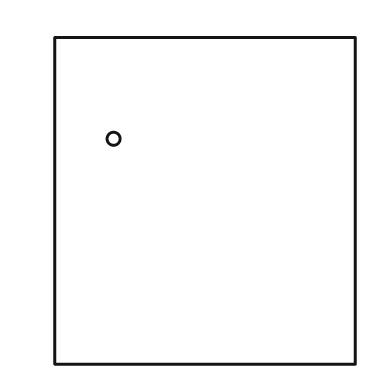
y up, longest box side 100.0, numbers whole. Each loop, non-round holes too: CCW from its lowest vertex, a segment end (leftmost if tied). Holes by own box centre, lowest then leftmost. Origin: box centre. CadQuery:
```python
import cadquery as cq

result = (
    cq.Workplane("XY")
    .moveTo(-46.0, -50.0)
    .lineTo(46.0, -50.0)
    .lineTo(46.0, 50.0)
    .lineTo(-46.0, 50.0)
    .close()
    .moveTo(-28.0, 19.0)
    .circle(2.0)
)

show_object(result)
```